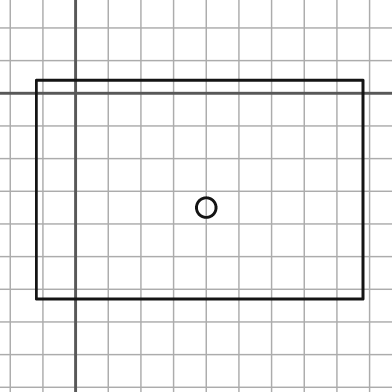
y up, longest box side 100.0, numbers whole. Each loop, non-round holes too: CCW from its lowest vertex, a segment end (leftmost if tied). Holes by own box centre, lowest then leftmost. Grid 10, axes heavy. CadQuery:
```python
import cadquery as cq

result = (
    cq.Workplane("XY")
    .moveTo(-12.0, -63.0)
    .lineTo(88.0, -63.0)
    .lineTo(88.0, 4.0)
    .lineTo(-12.0, 4.0)
    .close()
    .moveTo(40.0, -35.0)
    .circle(3.0)
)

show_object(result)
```